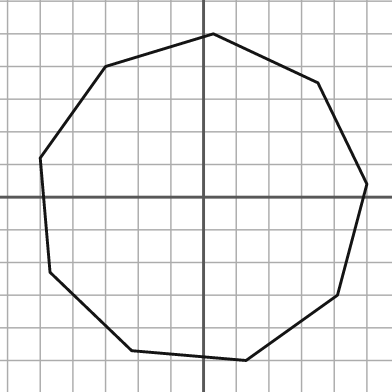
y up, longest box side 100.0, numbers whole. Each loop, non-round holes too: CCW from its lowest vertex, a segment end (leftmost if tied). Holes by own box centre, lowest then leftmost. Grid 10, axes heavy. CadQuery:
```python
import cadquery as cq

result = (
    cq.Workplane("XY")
    .moveTo(13.0, -50.0)
    .lineTo(41.0, -30.0)
    .lineTo(50.0, 4.0)
    .lineTo(35.0, 35.0)
    .lineTo(3.0, 50.0)
    .lineTo(-30.0, 40.0)
    .lineTo(-50.0, 12.0)
    .lineTo(-47.0, -23.0)
    .lineTo(-22.0, -47.0)
    .close()
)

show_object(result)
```